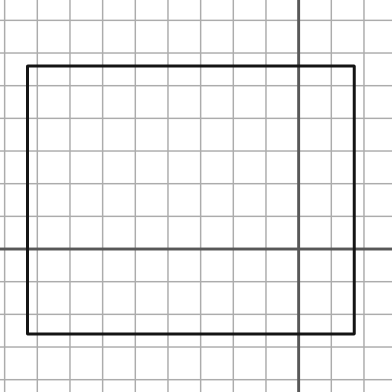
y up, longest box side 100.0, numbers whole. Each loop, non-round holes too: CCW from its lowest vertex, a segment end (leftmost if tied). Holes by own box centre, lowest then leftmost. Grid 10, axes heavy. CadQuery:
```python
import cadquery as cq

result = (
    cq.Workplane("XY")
    .moveTo(-83.0, -26.0)
    .lineTo(17.0, -26.0)
    .lineTo(17.0, 56.0)
    .lineTo(-83.0, 56.0)
    .close()
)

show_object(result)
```